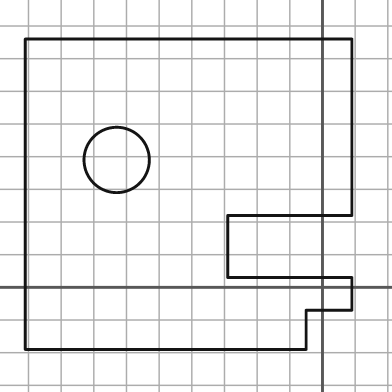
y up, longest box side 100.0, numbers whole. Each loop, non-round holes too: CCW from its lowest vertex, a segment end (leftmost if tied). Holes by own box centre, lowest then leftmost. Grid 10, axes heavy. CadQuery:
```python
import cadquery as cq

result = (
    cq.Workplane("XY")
    .moveTo(-91.0, -19.0)
    .lineTo(-5.0, -19.0)
    .lineTo(-5.0, -7.0)
    .lineTo(9.0, -7.0)
    .lineTo(9.0, 3.0)
    .lineTo(-29.0, 3.0)
    .lineTo(-29.0, 22.0)
    .lineTo(9.0, 22.0)
    .lineTo(9.0, 76.0)
    .lineTo(-91.0, 76.0)
    .close()
    .moveTo(-63.0, 39.0)
    .circle(10.0)
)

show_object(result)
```